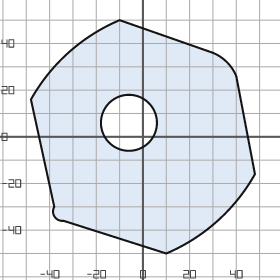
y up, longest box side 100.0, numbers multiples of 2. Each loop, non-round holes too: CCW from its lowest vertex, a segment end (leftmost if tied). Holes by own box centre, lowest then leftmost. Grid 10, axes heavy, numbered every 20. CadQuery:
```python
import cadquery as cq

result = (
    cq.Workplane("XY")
    .moveTo(10.0, -50.0)
    .threePointArc((32.0, -36.0), (48.0, -16.0))
    .lineTo(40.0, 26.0)
    .threePointArc((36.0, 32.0), (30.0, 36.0))
    .lineTo(-10.0, 50.0)
    .threePointArc((-32.0, 36.0), (-48.0, 16.0))
    .lineTo(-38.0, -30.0)
    .threePointArc((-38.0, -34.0), (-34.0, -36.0))
    .close()
    .moveTo(-6.0, 6.0)
    .circle(12.0)
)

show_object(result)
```